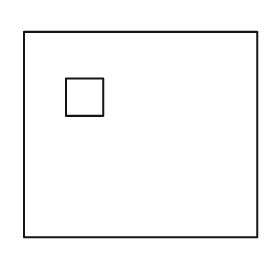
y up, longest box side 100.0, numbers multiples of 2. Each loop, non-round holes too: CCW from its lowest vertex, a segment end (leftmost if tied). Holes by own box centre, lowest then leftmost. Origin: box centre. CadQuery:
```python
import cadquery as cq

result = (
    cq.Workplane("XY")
    .moveTo(-50.0, -44.0)
    .lineTo(50.0, -44.0)
    .lineTo(50.0, 44.0)
    .lineTo(-50.0, 44.0)
    .close()
    .moveTo(-32.0, 8.0)
    .lineTo(-16.0, 8.0)
    .lineTo(-16.0, 24.0)
    .lineTo(-32.0, 24.0)
    .close()
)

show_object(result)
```